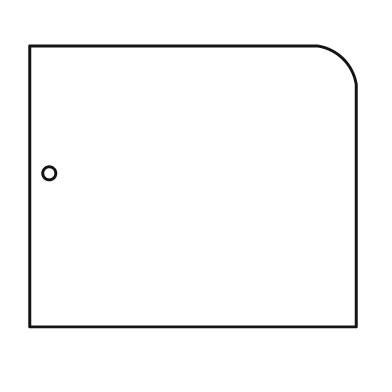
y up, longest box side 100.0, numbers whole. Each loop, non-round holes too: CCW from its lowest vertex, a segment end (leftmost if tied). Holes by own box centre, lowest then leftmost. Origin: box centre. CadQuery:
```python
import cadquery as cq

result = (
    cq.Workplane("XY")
    .moveTo(-50.0, -43.0)
    .lineTo(50.0, -43.0)
    .lineTo(50.0, 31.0)
    .threePointArc((46.0, 39.0), (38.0, 43.0))
    .lineTo(-50.0, 43.0)
    .close()
    .moveTo(-44.0, 4.0)
    .circle(2.0)
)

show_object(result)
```